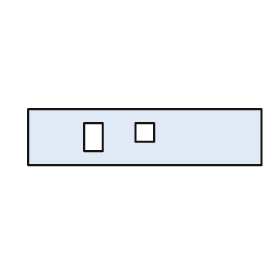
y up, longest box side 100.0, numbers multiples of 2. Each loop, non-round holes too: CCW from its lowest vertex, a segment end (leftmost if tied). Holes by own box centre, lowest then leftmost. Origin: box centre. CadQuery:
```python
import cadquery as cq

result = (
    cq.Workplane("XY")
    .moveTo(-50.0, -12.0)
    .lineTo(50.0, -12.0)
    .lineTo(50.0, 12.0)
    .lineTo(-50.0, 12.0)
    .close()
    .moveTo(-26.0, -6.0)
    .lineTo(-18.0, -6.0)
    .lineTo(-18.0, 6.0)
    .lineTo(-26.0, 6.0)
    .close()
    .moveTo(-4.0, -2.0)
    .lineTo(4.0, -2.0)
    .lineTo(4.0, 6.0)
    .lineTo(-4.0, 6.0)
    .close()
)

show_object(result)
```